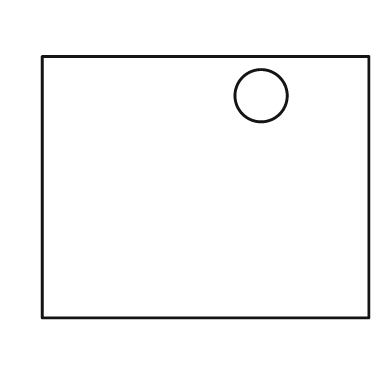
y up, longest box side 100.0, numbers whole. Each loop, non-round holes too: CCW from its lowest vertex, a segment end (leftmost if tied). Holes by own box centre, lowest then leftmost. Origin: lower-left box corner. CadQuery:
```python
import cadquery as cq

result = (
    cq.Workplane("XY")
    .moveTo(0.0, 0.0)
    .lineTo(100.0, 0.0)
    .lineTo(100.0, 80.0)
    .lineTo(0.0, 80.0)
    .close()
    .moveTo(67.0, 68.0)
    .circle(8.0)
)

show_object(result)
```